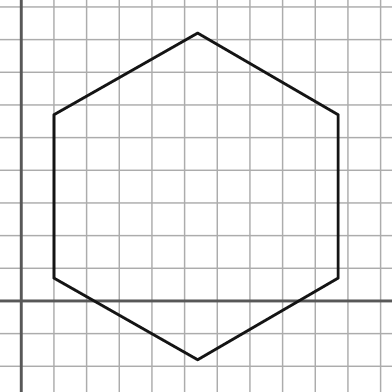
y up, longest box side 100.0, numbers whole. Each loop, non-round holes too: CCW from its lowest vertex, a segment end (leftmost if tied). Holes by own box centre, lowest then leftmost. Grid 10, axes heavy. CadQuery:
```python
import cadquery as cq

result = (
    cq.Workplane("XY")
    .moveTo(54.0, -18.0)
    .lineTo(97.0, 7.0)
    .lineTo(97.0, 57.0)
    .lineTo(54.0, 82.0)
    .lineTo(10.0, 57.0)
    .lineTo(10.0, 7.0)
    .close()
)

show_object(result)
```